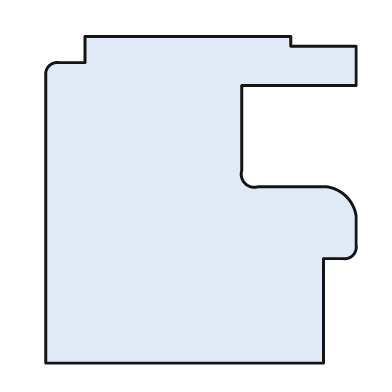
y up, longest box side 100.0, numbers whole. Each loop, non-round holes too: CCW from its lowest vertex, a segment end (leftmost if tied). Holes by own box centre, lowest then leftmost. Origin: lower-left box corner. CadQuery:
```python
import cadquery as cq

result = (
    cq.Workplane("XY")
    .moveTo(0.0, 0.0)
    .lineTo(85.0, 0.0)
    .lineTo(85.0, 32.0)
    .lineTo(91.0, 32.0)
    .threePointArc((94.0, 33.0), (95.0, 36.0))
    .lineTo(95.0, 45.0)
    .threePointArc((92.0, 51.0), (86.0, 54.0))
    .lineTo(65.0, 54.0)
    .threePointArc((61.0, 55.0), (60.0, 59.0))
    .lineTo(60.0, 85.0)
    .lineTo(95.0, 85.0)
    .lineTo(95.0, 97.0)
    .lineTo(75.0, 97.0)
    .lineTo(75.0, 100.0)
    .lineTo(12.0, 100.0)
    .lineTo(12.0, 92.0)
    .lineTo(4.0, 92.0)
    .threePointArc((1.0, 91.0), (0.0, 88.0))
    .close()
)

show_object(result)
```